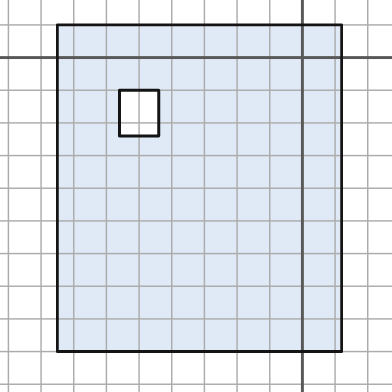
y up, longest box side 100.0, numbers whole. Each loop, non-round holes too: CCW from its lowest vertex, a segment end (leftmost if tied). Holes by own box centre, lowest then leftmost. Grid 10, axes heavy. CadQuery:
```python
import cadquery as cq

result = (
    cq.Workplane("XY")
    .moveTo(-75.0, -90.0)
    .lineTo(12.0, -90.0)
    .lineTo(12.0, 10.0)
    .lineTo(-75.0, 10.0)
    .close()
    .moveTo(-56.0, -24.0)
    .lineTo(-44.0, -24.0)
    .lineTo(-44.0, -10.0)
    .lineTo(-56.0, -10.0)
    .close()
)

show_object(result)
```